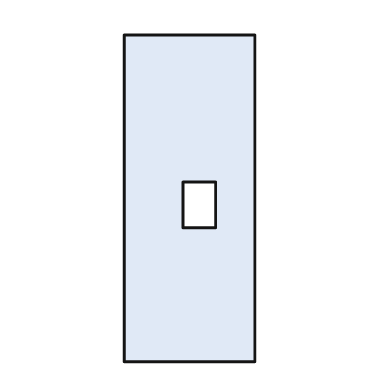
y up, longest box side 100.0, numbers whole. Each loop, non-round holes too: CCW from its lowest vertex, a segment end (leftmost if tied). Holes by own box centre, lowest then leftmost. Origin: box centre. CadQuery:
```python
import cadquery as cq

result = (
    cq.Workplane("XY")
    .moveTo(-20.0, -50.0)
    .lineTo(20.0, -50.0)
    .lineTo(20.0, 50.0)
    .lineTo(-20.0, 50.0)
    .close()
    .moveTo(-2.0, -9.0)
    .lineTo(8.0, -9.0)
    .lineTo(8.0, 5.0)
    .lineTo(-2.0, 5.0)
    .close()
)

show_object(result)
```